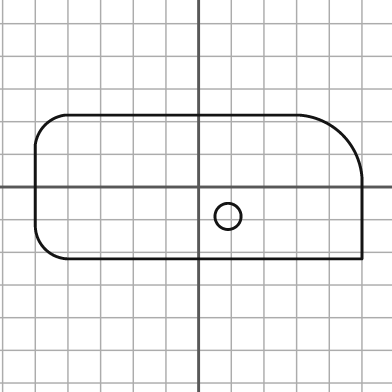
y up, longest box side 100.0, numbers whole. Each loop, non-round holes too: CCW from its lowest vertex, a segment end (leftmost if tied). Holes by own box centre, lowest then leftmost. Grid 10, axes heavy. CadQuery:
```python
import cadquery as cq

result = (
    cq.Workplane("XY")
    .moveTo(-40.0, -22.0)
    .lineTo(50.0, -22.0)
    .lineTo(50.0, 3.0)
    .threePointArc((44.0, 16.0), (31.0, 22.0))
    .lineTo(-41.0, 22.0)
    .threePointArc((-47.0, 19.0), (-50.0, 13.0))
    .lineTo(-50.0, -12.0)
    .threePointArc((-47.0, -19.0), (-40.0, -22.0))
    .close()
    .moveTo(9.0, -9.0)
    .circle(4.0)
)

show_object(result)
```